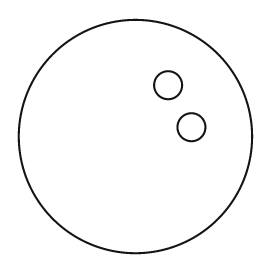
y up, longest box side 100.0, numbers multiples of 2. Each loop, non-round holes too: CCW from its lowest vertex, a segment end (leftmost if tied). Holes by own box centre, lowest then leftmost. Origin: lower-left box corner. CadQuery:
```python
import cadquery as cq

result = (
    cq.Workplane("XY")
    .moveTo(50.0, 50.0)
    .circle(50.0)
    .moveTo(74.0, 54.0)
    .circle(6.0)
    .moveTo(64.0, 72.0)
    .circle(6.0)
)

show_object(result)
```